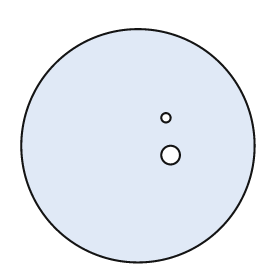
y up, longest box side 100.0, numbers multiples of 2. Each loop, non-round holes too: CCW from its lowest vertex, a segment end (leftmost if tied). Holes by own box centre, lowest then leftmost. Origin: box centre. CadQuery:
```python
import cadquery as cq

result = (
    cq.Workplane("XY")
    .moveTo(0.0, 0.0)
    .circle(50.0)
    .moveTo(14.0, -4.0)
    .circle(4.0)
    .moveTo(12.0, 12.0)
    .circle(2.0)
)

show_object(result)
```